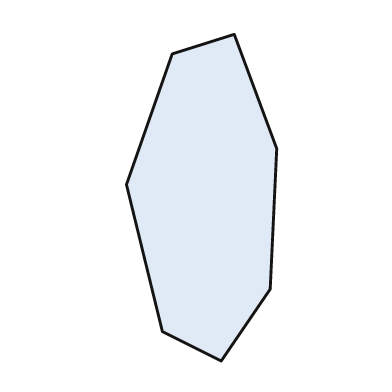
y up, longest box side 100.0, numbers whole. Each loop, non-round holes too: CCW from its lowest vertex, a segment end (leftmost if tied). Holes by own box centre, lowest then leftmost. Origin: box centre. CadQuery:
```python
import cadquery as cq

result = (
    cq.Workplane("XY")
    .moveTo(6.0, -50.0)
    .lineTo(21.0, -28.0)
    .lineTo(23.0, 15.0)
    .lineTo(10.0, 50.0)
    .lineTo(-9.0, 44.0)
    .lineTo(-23.0, 4.0)
    .lineTo(-12.0, -41.0)
    .close()
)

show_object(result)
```